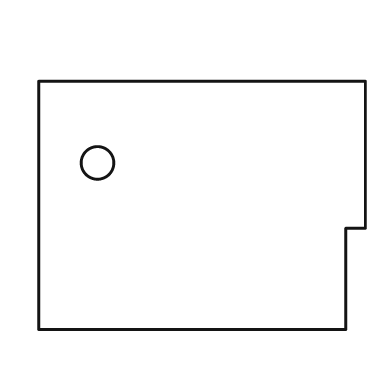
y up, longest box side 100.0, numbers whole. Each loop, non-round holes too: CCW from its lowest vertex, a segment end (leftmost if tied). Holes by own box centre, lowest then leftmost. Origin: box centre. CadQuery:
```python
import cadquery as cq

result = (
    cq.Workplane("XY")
    .moveTo(-50.0, -38.0)
    .lineTo(44.0, -38.0)
    .lineTo(44.0, -7.0)
    .lineTo(50.0, -7.0)
    .lineTo(50.0, 38.0)
    .lineTo(-50.0, 38.0)
    .close()
    .moveTo(-32.0, 13.0)
    .circle(5.0)
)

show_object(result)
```